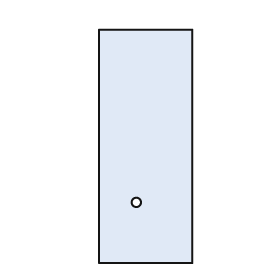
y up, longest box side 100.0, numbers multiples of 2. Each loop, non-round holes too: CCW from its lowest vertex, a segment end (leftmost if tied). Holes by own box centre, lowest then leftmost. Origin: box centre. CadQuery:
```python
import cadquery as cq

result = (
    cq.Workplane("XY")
    .moveTo(-20.0, -50.0)
    .lineTo(20.0, -50.0)
    .lineTo(20.0, 50.0)
    .lineTo(-20.0, 50.0)
    .close()
    .moveTo(-4.0, -24.0)
    .circle(2.0)
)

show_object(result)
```